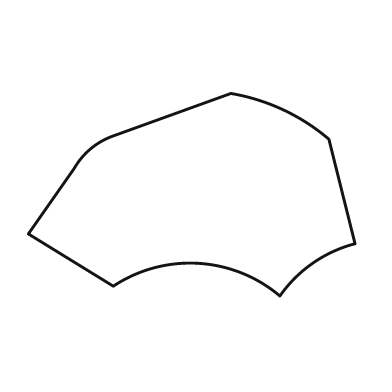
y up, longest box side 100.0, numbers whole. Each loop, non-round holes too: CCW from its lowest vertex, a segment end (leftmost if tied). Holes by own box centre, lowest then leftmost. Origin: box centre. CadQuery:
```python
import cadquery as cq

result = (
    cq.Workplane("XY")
    .moveTo(27.0, -31.0)
    .threePointArc((37.0, -21.0), (50.0, -15.0))
    .lineTo(42.0, 17.0)
    .threePointArc((28.0, 26.0), (12.0, 31.0))
    .lineTo(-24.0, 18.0)
    .threePointArc((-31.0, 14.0), (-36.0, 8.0))
    .lineTo(-50.0, -12.0)
    .lineTo(-24.0, -28.0)
    .threePointArc((2.0, -21.0), (27.0, -31.0))
    .close()
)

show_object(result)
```